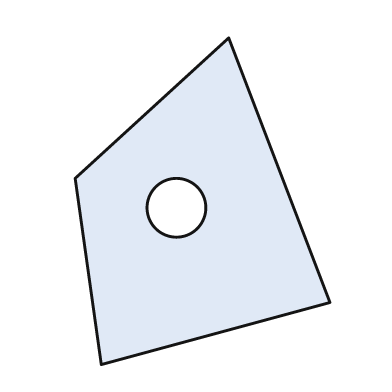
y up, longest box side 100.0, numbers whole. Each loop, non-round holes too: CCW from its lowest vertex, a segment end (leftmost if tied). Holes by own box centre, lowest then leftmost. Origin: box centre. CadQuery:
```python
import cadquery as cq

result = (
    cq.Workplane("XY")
    .moveTo(-31.0, -50.0)
    .lineTo(39.0, -31.0)
    .lineTo(8.0, 50.0)
    .lineTo(-39.0, 7.0)
    .close()
    .moveTo(-8.0, -2.0)
    .circle(9.0)
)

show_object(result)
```